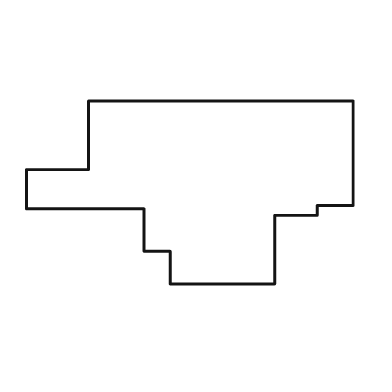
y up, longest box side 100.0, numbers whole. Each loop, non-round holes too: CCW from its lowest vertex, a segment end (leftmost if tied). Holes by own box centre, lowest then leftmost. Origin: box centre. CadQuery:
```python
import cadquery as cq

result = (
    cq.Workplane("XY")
    .moveTo(-6.0, -28.0)
    .lineTo(26.0, -28.0)
    .lineTo(26.0, -7.0)
    .lineTo(39.0, -7.0)
    .lineTo(39.0, -4.0)
    .lineTo(50.0, -4.0)
    .lineTo(50.0, 28.0)
    .lineTo(-31.0, 28.0)
    .lineTo(-31.0, 7.0)
    .lineTo(-50.0, 7.0)
    .lineTo(-50.0, -5.0)
    .lineTo(-14.0, -5.0)
    .lineTo(-14.0, -18.0)
    .lineTo(-6.0, -18.0)
    .close()
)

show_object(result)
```